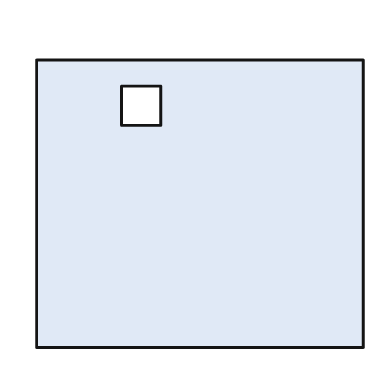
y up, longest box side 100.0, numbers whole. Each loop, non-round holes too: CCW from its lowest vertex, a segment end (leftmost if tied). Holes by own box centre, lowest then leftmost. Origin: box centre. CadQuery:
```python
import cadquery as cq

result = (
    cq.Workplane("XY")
    .moveTo(-50.0, -44.0)
    .lineTo(50.0, -44.0)
    .lineTo(50.0, 44.0)
    .lineTo(-50.0, 44.0)
    .close()
    .moveTo(-24.0, 24.0)
    .lineTo(-12.0, 24.0)
    .lineTo(-12.0, 36.0)
    .lineTo(-24.0, 36.0)
    .close()
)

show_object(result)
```